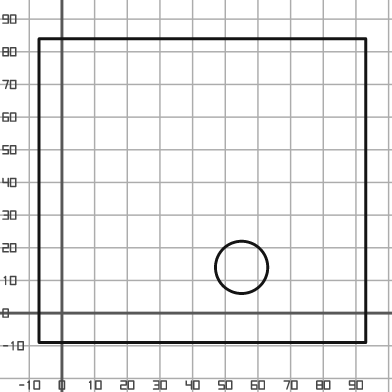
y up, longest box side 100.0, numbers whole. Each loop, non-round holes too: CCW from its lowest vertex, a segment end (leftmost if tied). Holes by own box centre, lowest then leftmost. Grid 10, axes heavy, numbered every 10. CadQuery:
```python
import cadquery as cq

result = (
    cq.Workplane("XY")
    .moveTo(-7.0, -9.0)
    .lineTo(93.0, -9.0)
    .lineTo(93.0, 84.0)
    .lineTo(-7.0, 84.0)
    .close()
    .moveTo(55.0, 14.0)
    .circle(8.0)
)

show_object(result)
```